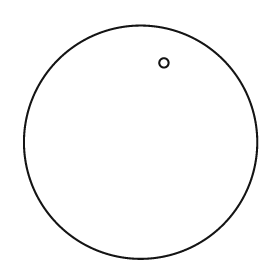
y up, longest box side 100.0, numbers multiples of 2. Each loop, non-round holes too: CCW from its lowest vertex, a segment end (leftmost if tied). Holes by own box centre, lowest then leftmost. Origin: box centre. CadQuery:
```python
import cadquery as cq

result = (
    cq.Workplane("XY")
    .moveTo(0.0, 0.0)
    .circle(50.0)
    .moveTo(10.0, 34.0)
    .circle(2.0)
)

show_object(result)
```